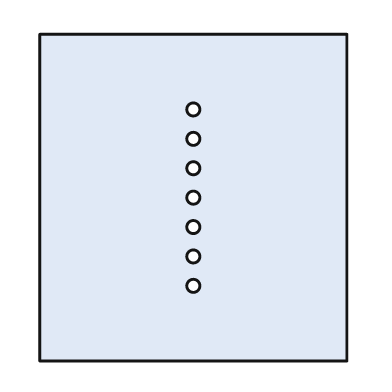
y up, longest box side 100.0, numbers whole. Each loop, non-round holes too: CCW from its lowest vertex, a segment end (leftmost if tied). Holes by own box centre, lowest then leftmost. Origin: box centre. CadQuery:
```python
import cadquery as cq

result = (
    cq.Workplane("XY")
    .moveTo(-47.0, -50.0)
    .lineTo(47.0, -50.0)
    .lineTo(47.0, 50.0)
    .lineTo(-47.0, 50.0)
    .close()
    .moveTo(0.0, -27.0)
    .circle(2.0)
    .moveTo(0.0, -18.0)
    .circle(2.0)
    .moveTo(0.0, -9.0)
    .circle(2.0)
    .moveTo(0.0, 0.0)
    .circle(2.0)
    .moveTo(0.0, 9.0)
    .circle(2.0)
    .moveTo(0.0, 18.0)
    .circle(2.0)
    .moveTo(0.0, 27.0)
    .circle(2.0)
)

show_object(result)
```